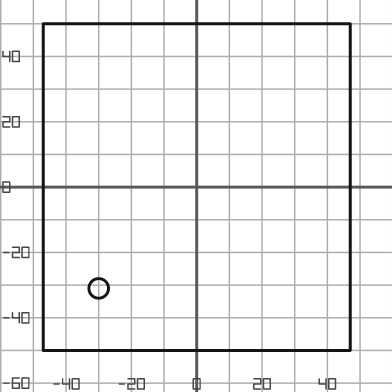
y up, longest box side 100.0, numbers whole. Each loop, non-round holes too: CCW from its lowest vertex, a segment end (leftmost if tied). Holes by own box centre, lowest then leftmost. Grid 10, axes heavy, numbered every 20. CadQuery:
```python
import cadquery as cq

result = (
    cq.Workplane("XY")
    .moveTo(-47.0, -50.0)
    .lineTo(47.0, -50.0)
    .lineTo(47.0, 50.0)
    .lineTo(-47.0, 50.0)
    .close()
    .moveTo(-30.0, -31.0)
    .circle(3.0)
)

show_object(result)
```